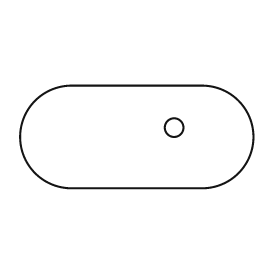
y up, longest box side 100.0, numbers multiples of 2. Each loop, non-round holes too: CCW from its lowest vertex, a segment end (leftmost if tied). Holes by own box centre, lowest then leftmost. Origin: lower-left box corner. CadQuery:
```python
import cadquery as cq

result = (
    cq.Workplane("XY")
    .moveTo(22.0, 0.0)
    .lineTo(78.0, 0.0)
    .threePointArc((100.0, 22.0), (78.0, 44.0))
    .lineTo(22.0, 44.0)
    .threePointArc((0.0, 22.0), (22.0, 0.0))
    .close()
    .moveTo(66.0, 26.0)
    .circle(4.0)
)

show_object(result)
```